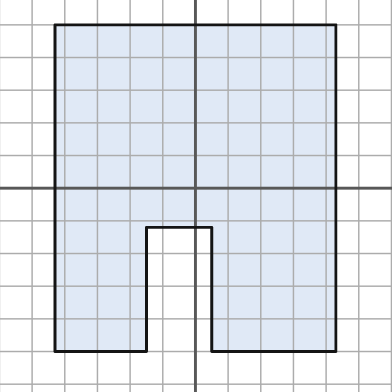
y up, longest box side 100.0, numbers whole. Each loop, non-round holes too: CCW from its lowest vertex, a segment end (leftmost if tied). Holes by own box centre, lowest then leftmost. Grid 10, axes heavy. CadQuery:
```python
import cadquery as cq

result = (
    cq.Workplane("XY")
    .moveTo(-43.0, -50.0)
    .lineTo(-15.0, -50.0)
    .lineTo(-15.0, -12.0)
    .lineTo(5.0, -12.0)
    .lineTo(5.0, -50.0)
    .lineTo(43.0, -50.0)
    .lineTo(43.0, 50.0)
    .lineTo(-43.0, 50.0)
    .close()
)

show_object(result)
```